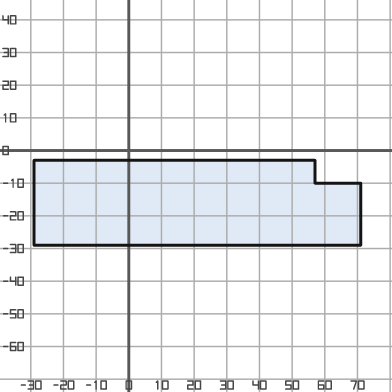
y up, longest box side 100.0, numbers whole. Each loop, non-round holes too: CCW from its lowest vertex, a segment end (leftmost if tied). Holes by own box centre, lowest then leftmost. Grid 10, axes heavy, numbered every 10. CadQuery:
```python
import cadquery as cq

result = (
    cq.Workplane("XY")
    .moveTo(-29.0, -29.0)
    .lineTo(71.0, -29.0)
    .lineTo(71.0, -10.0)
    .lineTo(57.0, -10.0)
    .lineTo(57.0, -3.0)
    .lineTo(-29.0, -3.0)
    .close()
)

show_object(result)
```